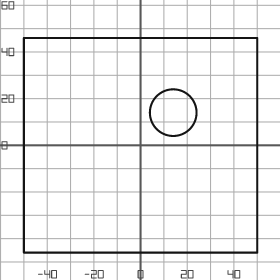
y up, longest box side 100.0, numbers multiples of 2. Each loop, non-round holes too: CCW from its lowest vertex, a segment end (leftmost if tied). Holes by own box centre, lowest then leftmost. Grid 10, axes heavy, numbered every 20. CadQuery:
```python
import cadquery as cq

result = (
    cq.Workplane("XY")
    .moveTo(-50.0, -46.0)
    .lineTo(50.0, -46.0)
    .lineTo(50.0, 46.0)
    .lineTo(-50.0, 46.0)
    .close()
    .moveTo(14.0, 14.0)
    .circle(10.0)
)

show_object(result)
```